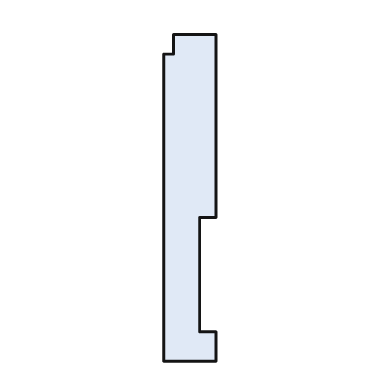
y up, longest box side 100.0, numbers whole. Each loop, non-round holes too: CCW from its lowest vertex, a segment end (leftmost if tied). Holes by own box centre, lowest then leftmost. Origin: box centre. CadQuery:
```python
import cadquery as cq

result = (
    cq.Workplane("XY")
    .moveTo(-8.0, -50.0)
    .lineTo(8.0, -50.0)
    .lineTo(8.0, -41.0)
    .lineTo(3.0, -41.0)
    .lineTo(3.0, -6.0)
    .lineTo(8.0, -6.0)
    .lineTo(8.0, 50.0)
    .lineTo(-5.0, 50.0)
    .lineTo(-5.0, 44.0)
    .lineTo(-8.0, 44.0)
    .close()
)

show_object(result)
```